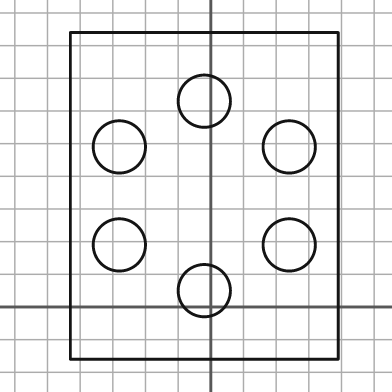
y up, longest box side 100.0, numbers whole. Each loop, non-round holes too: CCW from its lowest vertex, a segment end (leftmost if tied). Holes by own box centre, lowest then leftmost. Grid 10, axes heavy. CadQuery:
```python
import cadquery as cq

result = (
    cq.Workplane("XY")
    .moveTo(-43.0, -16.0)
    .lineTo(39.0, -16.0)
    .lineTo(39.0, 84.0)
    .lineTo(-43.0, 84.0)
    .close()
    .moveTo(-2.0, 5.0)
    .circle(8.0)
    .moveTo(-28.0, 19.0)
    .circle(8.0)
    .moveTo(24.0, 19.0)
    .circle(8.0)
    .moveTo(-28.0, 49.0)
    .circle(8.0)
    .moveTo(24.0, 49.0)
    .circle(8.0)
    .moveTo(-2.0, 63.0)
    .circle(8.0)
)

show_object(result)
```